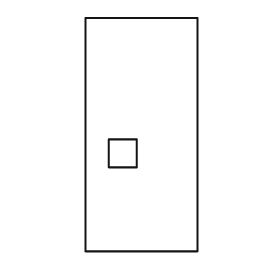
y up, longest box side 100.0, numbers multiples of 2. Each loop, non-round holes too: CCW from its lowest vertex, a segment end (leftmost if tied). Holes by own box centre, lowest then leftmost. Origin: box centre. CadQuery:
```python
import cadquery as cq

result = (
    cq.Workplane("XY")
    .moveTo(-24.0, -50.0)
    .lineTo(24.0, -50.0)
    .lineTo(24.0, 50.0)
    .lineTo(-24.0, 50.0)
    .close()
    .moveTo(-14.0, -14.0)
    .lineTo(-2.0, -14.0)
    .lineTo(-2.0, -2.0)
    .lineTo(-14.0, -2.0)
    .close()
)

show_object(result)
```